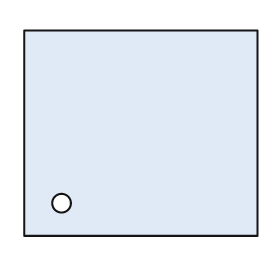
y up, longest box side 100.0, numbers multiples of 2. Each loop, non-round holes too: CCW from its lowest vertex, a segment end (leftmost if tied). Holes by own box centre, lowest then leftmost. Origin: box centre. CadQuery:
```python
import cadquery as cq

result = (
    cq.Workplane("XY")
    .moveTo(-50.0, -44.0)
    .lineTo(50.0, -44.0)
    .lineTo(50.0, 44.0)
    .lineTo(-50.0, 44.0)
    .close()
    .moveTo(-34.0, -30.0)
    .circle(4.0)
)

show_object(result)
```